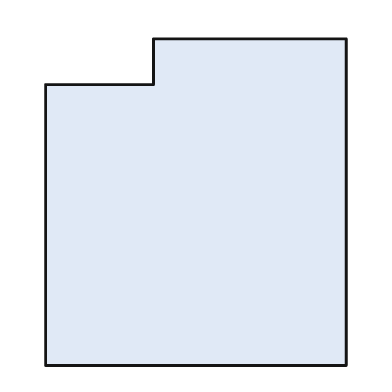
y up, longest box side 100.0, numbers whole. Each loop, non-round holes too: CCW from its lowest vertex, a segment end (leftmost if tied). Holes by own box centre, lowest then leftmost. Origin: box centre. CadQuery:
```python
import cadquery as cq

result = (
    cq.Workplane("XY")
    .moveTo(-46.0, -50.0)
    .lineTo(46.0, -50.0)
    .lineTo(46.0, 50.0)
    .lineTo(-13.0, 50.0)
    .lineTo(-13.0, 36.0)
    .lineTo(-46.0, 36.0)
    .close()
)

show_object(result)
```